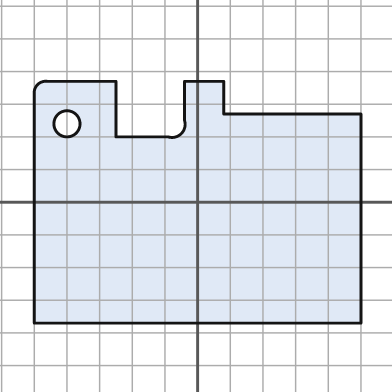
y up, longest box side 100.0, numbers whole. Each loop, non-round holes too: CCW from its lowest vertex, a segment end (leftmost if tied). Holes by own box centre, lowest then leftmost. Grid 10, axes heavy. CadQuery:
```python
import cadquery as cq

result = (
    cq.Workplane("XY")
    .moveTo(-50.0, -37.0)
    .lineTo(50.0, -37.0)
    .lineTo(50.0, 27.0)
    .lineTo(8.0, 27.0)
    .lineTo(8.0, 37.0)
    .lineTo(-4.0, 37.0)
    .lineTo(-4.0, 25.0)
    .threePointArc((-5.0, 21.0), (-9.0, 20.0))
    .lineTo(-25.0, 20.0)
    .lineTo(-25.0, 37.0)
    .lineTo(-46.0, 37.0)
    .threePointArc((-49.0, 36.0), (-50.0, 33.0))
    .close()
    .moveTo(-40.0, 24.0)
    .circle(4.0)
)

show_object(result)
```